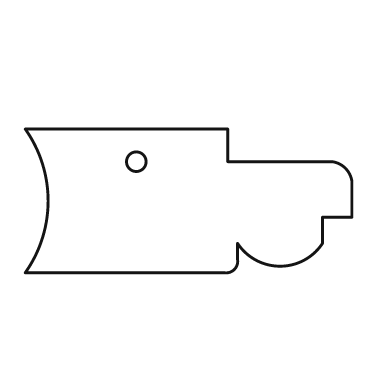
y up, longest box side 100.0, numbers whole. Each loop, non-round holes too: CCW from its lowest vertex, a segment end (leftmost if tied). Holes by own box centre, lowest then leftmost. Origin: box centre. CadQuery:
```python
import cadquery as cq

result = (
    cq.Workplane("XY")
    .moveTo(-50.0, -22.0)
    .lineTo(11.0, -22.0)
    .threePointArc((14.0, -21.0), (15.0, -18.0))
    .lineTo(15.0, -13.0)
    .threePointArc((28.0, -20.0), (41.0, -13.0))
    .lineTo(41.0, -5.0)
    .lineTo(50.0, -5.0)
    .lineTo(50.0, 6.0)
    .threePointArc((48.0, 10.0), (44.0, 12.0))
    .lineTo(12.0, 12.0)
    .lineTo(12.0, 22.0)
    .lineTo(-50.0, 22.0)
    .threePointArc((-43.0, 0.0), (-50.0, -22.0))
    .close()
    .moveTo(-16.0, 12.0)
    .circle(3.0)
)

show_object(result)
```